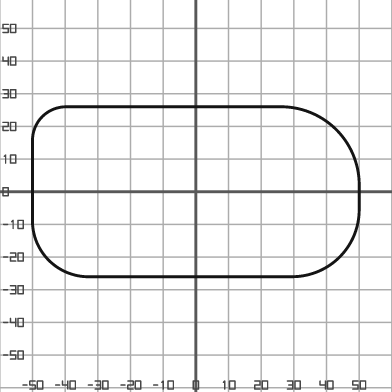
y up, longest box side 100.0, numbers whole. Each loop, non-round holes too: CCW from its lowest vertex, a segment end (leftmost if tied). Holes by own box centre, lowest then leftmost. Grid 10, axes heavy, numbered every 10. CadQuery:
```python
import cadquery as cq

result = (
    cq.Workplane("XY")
    .moveTo(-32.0, -26.0)
    .lineTo(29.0, -26.0)
    .threePointArc((44.0, -20.0), (50.0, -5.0))
    .lineTo(50.0, 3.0)
    .threePointArc((43.0, 19.0), (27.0, 26.0))
    .lineTo(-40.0, 26.0)
    .threePointArc((-47.0, 23.0), (-50.0, 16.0))
    .lineTo(-50.0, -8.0)
    .threePointArc((-45.0, -21.0), (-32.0, -26.0))
    .close()
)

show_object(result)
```